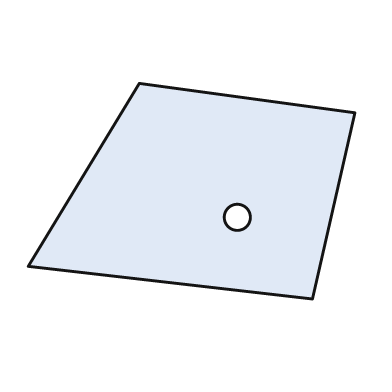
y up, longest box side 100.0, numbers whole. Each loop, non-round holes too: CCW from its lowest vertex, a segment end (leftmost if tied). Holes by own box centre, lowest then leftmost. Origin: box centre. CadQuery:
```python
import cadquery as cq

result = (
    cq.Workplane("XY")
    .moveTo(37.0, -33.0)
    .lineTo(50.0, 24.0)
    .lineTo(-16.0, 33.0)
    .lineTo(-50.0, -23.0)
    .close()
    .moveTo(14.0, -8.0)
    .circle(4.0)
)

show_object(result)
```